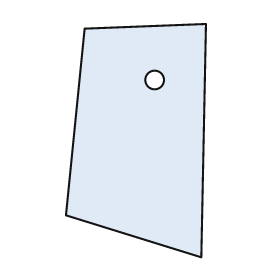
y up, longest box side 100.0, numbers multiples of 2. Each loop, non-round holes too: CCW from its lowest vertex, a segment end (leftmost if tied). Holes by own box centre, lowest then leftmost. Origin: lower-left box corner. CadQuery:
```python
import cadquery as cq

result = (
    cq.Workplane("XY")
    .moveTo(58.0, 0.0)
    .lineTo(60.0, 100.0)
    .lineTo(8.0, 98.0)
    .lineTo(0.0, 18.0)
    .close()
    .moveTo(38.0, 76.0)
    .circle(4.0)
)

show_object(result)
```